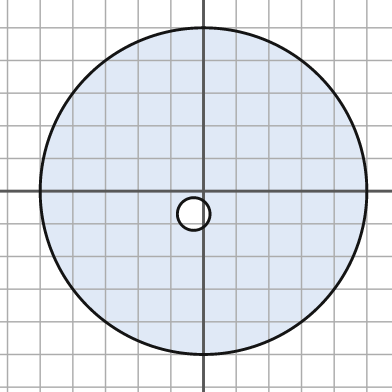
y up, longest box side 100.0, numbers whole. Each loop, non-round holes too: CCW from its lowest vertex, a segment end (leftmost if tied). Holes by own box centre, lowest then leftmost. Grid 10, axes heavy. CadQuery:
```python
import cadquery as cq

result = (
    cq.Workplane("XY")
    .moveTo(0.0, 0.0)
    .circle(50.0)
    .moveTo(-3.0, -7.0)
    .circle(5.0)
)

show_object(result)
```